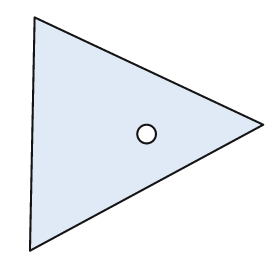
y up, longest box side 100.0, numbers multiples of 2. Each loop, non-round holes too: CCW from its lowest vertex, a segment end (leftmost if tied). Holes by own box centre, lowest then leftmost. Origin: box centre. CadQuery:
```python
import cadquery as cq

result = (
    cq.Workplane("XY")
    .moveTo(-50.0, -50.0)
    .lineTo(50.0, 4.0)
    .lineTo(-48.0, 50.0)
    .close()
    .moveTo(0.0, 0.0)
    .circle(4.0)
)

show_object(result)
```